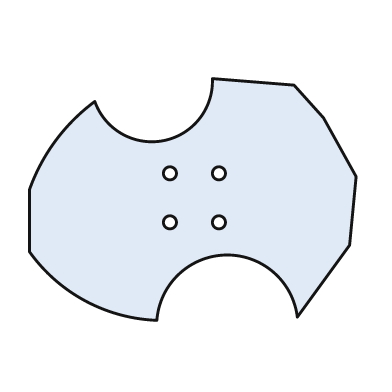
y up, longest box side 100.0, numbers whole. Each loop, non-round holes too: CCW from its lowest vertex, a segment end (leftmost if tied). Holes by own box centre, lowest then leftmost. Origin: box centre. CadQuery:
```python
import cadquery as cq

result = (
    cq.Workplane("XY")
    .moveTo(-11.0, -37.0)
    .threePointArc((10.0, -17.0), (32.0, -36.0))
    .lineTo(48.0, -14.0)
    .lineTo(50.0, 7.0)
    .lineTo(40.0, 25.0)
    .lineTo(31.0, 35.0)
    .lineTo(6.0, 37.0)
    .threePointArc((-9.0, 18.0), (-30.0, 30.0))
    .threePointArc((-42.0, 18.0), (-50.0, 3.0))
    .lineTo(-50.0, -16.0)
    .threePointArc((-33.0, -31.0), (-11.0, -37.0))
    .close()
    .moveTo(-7.0, -7.0)
    .circle(2.0)
    .moveTo(8.0, -7.0)
    .circle(2.0)
    .moveTo(-7.0, 8.0)
    .circle(2.0)
    .moveTo(8.0, 8.0)
    .circle(2.0)
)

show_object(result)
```